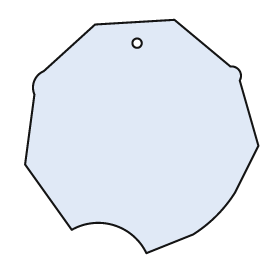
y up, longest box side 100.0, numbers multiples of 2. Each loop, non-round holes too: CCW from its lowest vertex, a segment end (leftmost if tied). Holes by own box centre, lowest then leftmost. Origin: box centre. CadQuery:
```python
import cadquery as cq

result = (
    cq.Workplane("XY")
    .moveTo(2.0, -50.0)
    .lineTo(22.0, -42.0)
    .threePointArc((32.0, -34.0), (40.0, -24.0))
    .lineTo(50.0, -4.0)
    .lineTo(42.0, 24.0)
    .threePointArc((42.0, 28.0), (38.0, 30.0))
    .lineTo(14.0, 50.0)
    .lineTo(-20.0, 48.0)
    .lineTo(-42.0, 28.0)
    .threePointArc((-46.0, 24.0), (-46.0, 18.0))
    .lineTo(-50.0, -12.0)
    .lineTo(-30.0, -40.0)
    .threePointArc((-12.0, -38.0), (2.0, -50.0))
    .close()
    .moveTo(-2.0, 40.0)
    .circle(2.0)
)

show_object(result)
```